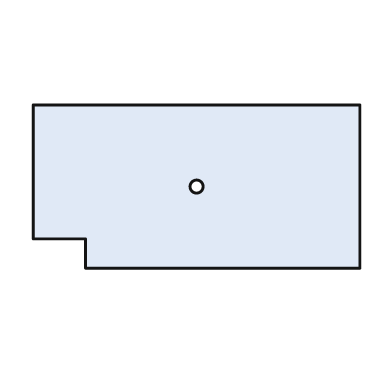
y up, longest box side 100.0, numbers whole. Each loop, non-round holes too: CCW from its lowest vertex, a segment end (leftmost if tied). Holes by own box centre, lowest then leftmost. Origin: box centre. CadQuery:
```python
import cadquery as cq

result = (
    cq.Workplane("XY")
    .moveTo(-34.0, -25.0)
    .lineTo(50.0, -25.0)
    .lineTo(50.0, 25.0)
    .lineTo(-50.0, 25.0)
    .lineTo(-50.0, -16.0)
    .lineTo(-34.0, -16.0)
    .close()
    .moveTo(0.0, 0.0)
    .circle(2.0)
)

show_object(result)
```